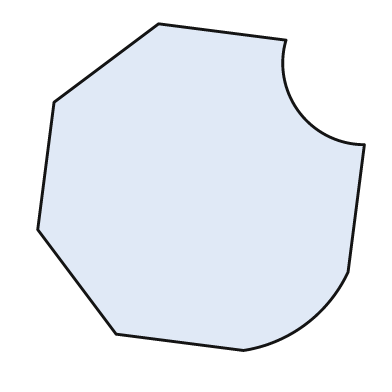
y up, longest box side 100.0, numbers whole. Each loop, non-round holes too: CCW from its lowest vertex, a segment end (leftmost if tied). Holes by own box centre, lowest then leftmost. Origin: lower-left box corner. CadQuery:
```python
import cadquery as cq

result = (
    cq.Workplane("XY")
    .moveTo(63.0, 0.0)
    .threePointArc((82.0, 8.0), (95.0, 24.0))
    .lineTo(100.0, 63.0)
    .threePointArc((80.0, 73.0), (76.0, 95.0))
    .lineTo(37.0, 100.0)
    .lineTo(5.0, 76.0)
    .lineTo(0.0, 37.0)
    .lineTo(24.0, 5.0)
    .close()
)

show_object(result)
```